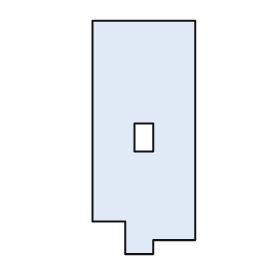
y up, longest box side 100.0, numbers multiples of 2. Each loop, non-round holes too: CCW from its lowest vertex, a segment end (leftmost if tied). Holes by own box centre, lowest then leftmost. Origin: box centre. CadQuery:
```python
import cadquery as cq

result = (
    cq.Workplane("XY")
    .moveTo(-8.0, -50.0)
    .lineTo(4.0, -50.0)
    .lineTo(4.0, -44.0)
    .lineTo(22.0, -44.0)
    .lineTo(22.0, 50.0)
    .lineTo(-22.0, 50.0)
    .lineTo(-22.0, -36.0)
    .lineTo(-8.0, -36.0)
    .close()
    .moveTo(-4.0, -6.0)
    .lineTo(4.0, -6.0)
    .lineTo(4.0, 6.0)
    .lineTo(-4.0, 6.0)
    .close()
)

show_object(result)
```